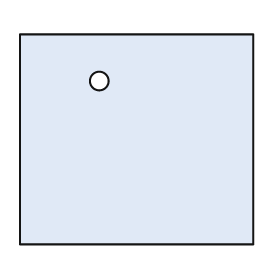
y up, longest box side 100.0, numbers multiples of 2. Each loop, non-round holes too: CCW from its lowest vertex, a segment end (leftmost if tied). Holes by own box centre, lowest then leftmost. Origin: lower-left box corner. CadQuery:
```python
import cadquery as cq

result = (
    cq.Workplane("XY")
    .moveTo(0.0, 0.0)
    .lineTo(100.0, 0.0)
    .lineTo(100.0, 90.0)
    .lineTo(0.0, 90.0)
    .close()
    .moveTo(34.0, 70.0)
    .circle(4.0)
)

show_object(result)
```